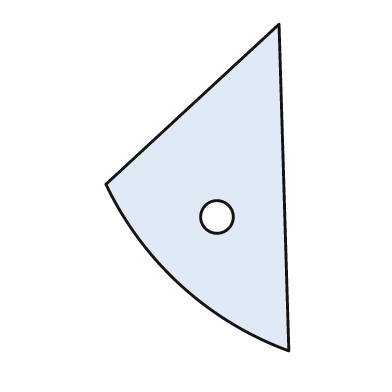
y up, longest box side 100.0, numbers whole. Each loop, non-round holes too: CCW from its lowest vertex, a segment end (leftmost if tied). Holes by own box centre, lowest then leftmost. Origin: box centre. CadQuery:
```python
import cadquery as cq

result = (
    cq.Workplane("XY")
    .moveTo(28.0, -50.0)
    .lineTo(25.0, 50.0)
    .lineTo(-28.0, 1.0)
    .threePointArc((-5.0, -30.0), (28.0, -50.0))
    .close()
    .moveTo(6.0, -9.0)
    .circle(5.0)
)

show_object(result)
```